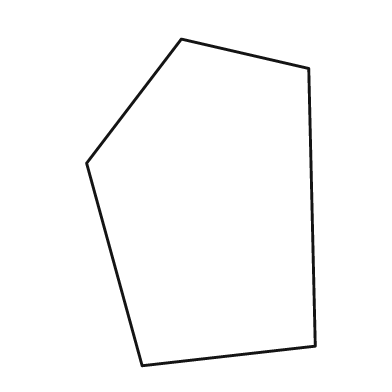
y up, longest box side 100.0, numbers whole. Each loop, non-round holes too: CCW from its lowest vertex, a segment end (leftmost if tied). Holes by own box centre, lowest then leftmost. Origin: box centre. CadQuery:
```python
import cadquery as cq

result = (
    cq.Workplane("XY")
    .moveTo(-18.0, -50.0)
    .lineTo(35.0, -44.0)
    .lineTo(33.0, 41.0)
    .lineTo(-6.0, 50.0)
    .lineTo(-35.0, 12.0)
    .close()
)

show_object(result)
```